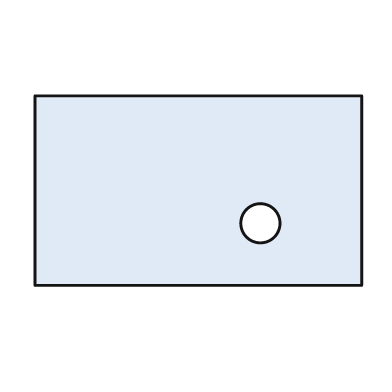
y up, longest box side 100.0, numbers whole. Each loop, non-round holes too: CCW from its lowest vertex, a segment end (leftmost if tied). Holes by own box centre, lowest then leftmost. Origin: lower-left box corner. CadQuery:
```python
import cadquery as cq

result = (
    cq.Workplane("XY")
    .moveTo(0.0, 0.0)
    .lineTo(100.0, 0.0)
    .lineTo(100.0, 58.0)
    .lineTo(0.0, 58.0)
    .close()
    .moveTo(69.0, 19.0)
    .circle(6.0)
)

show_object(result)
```